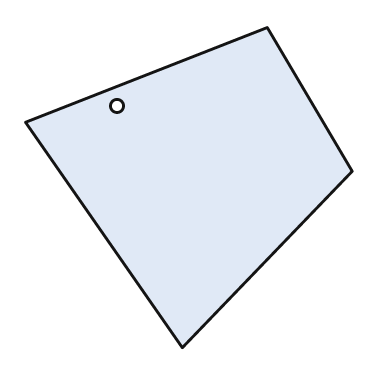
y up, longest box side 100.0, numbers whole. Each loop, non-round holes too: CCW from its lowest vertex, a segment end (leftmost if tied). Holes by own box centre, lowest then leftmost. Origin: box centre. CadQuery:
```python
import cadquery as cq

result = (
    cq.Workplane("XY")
    .moveTo(-2.0, -49.0)
    .lineTo(50.0, 5.0)
    .lineTo(24.0, 49.0)
    .lineTo(-50.0, 20.0)
    .close()
    .moveTo(-22.0, 25.0)
    .circle(2.0)
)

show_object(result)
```